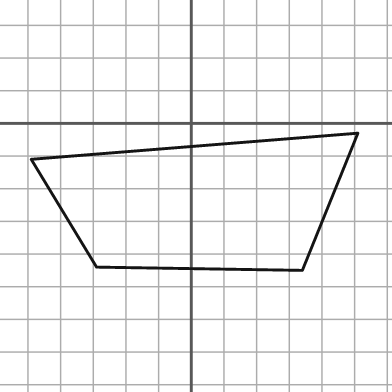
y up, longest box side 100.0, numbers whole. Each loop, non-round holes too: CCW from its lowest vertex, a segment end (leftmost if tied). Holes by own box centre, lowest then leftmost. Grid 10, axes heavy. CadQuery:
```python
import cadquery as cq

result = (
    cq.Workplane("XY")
    .moveTo(34.0, -45.0)
    .lineTo(51.0, -3.0)
    .lineTo(-49.0, -11.0)
    .lineTo(-29.0, -44.0)
    .close()
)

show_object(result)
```